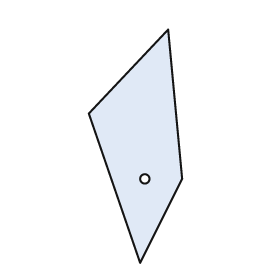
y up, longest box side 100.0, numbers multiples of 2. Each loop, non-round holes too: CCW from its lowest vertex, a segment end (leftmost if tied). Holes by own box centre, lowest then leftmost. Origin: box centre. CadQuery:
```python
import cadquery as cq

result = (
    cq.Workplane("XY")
    .moveTo(2.0, -50.0)
    .lineTo(20.0, -14.0)
    .lineTo(14.0, 50.0)
    .lineTo(-20.0, 14.0)
    .close()
    .moveTo(4.0, -14.0)
    .circle(2.0)
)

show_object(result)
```